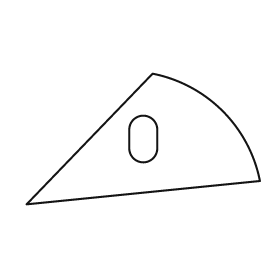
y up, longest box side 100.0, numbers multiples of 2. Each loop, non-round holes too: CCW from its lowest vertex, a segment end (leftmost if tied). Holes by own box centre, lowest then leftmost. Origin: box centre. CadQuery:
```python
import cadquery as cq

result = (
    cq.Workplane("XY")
    .moveTo(-50.0, -28.0)
    .lineTo(50.0, -18.0)
    .threePointArc((34.0, 12.0), (4.0, 28.0))
    .close()
    .moveTo(-6.0, -4.0)
    .threePointArc((0.0, -10.0), (6.0, -4.0))
    .lineTo(6.0, 4.0)
    .threePointArc((0.0, 10.0), (-6.0, 4.0))
    .close()
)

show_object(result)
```